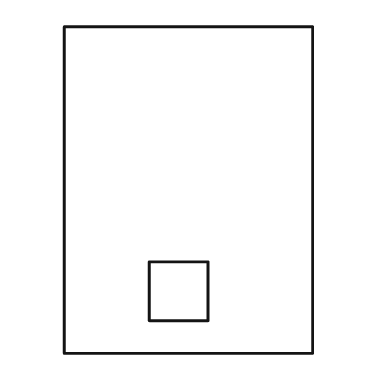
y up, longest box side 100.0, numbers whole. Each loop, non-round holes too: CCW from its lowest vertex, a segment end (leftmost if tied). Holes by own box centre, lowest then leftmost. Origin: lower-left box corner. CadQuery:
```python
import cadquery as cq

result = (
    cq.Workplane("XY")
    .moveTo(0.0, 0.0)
    .lineTo(76.0, 0.0)
    .lineTo(76.0, 100.0)
    .lineTo(0.0, 100.0)
    .close()
    .moveTo(26.0, 10.0)
    .lineTo(44.0, 10.0)
    .lineTo(44.0, 28.0)
    .lineTo(26.0, 28.0)
    .close()
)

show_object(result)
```